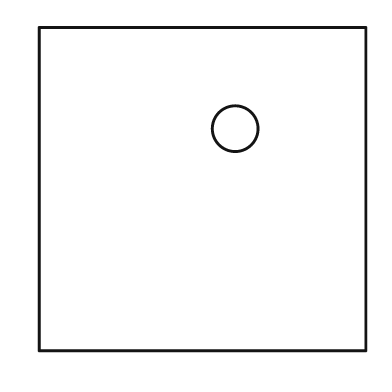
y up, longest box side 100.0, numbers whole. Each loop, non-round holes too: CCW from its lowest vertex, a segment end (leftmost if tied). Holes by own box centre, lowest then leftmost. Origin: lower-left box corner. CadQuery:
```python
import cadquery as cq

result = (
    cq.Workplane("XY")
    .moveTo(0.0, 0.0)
    .lineTo(100.0, 0.0)
    .lineTo(100.0, 99.0)
    .lineTo(0.0, 99.0)
    .close()
    .moveTo(60.0, 68.0)
    .circle(7.0)
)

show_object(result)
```